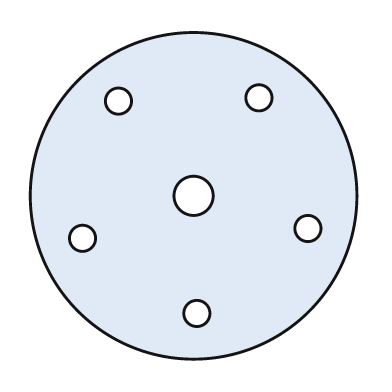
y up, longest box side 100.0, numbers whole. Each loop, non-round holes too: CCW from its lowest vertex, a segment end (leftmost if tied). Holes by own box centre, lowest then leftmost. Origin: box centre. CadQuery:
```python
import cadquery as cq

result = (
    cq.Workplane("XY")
    .moveTo(0.0, 0.0)
    .circle(50.0)
    .moveTo(1.0, -36.0)
    .circle(4.0)
    .moveTo(-34.0, -13.0)
    .circle(4.0)
    .moveTo(35.0, -10.0)
    .circle(4.0)
    .moveTo(0.0, 0.0)
    .circle(6.0)
    .moveTo(-23.0, 29.0)
    .circle(4.0)
    .moveTo(20.0, 30.0)
    .circle(4.0)
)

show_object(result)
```